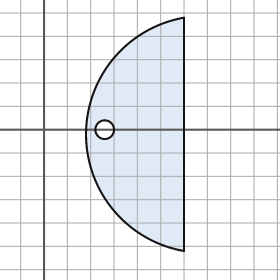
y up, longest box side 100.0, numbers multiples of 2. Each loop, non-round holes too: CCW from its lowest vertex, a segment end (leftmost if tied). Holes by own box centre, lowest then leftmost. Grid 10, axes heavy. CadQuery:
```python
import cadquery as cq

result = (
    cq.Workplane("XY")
    .moveTo(60.0, -52.0)
    .lineTo(60.0, 48.0)
    .threePointArc((18.0, -2.0), (60.0, -52.0))
    .close()
    .moveTo(26.0, 0.0)
    .circle(4.0)
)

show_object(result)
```